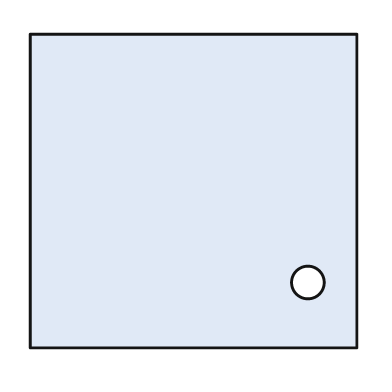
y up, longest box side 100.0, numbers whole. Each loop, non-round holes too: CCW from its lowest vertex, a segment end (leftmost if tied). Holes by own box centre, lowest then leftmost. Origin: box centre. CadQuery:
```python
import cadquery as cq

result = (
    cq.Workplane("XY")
    .moveTo(-50.0, -48.0)
    .lineTo(50.0, -48.0)
    .lineTo(50.0, 48.0)
    .lineTo(-50.0, 48.0)
    .close()
    .moveTo(35.0, -28.0)
    .circle(5.0)
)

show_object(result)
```